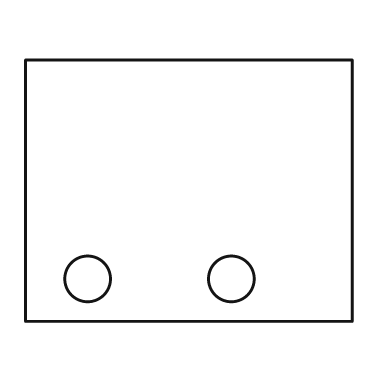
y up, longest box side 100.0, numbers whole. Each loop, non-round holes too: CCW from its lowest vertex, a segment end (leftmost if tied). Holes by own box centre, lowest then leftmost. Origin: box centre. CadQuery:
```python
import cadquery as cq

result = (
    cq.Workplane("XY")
    .moveTo(-50.0, -40.0)
    .lineTo(50.0, -40.0)
    .lineTo(50.0, 40.0)
    .lineTo(-50.0, 40.0)
    .close()
    .moveTo(-31.0, -27.0)
    .circle(7.0)
    .moveTo(13.0, -27.0)
    .circle(7.0)
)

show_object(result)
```